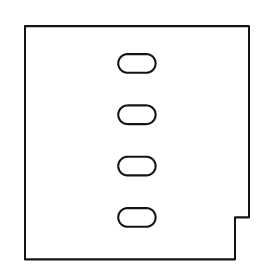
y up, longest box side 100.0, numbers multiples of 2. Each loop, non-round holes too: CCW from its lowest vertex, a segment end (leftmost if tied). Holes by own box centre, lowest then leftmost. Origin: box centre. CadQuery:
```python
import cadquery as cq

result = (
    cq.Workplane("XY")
    .moveTo(-48.0, -50.0)
    .lineTo(42.0, -50.0)
    .lineTo(42.0, -32.0)
    .lineTo(48.0, -32.0)
    .lineTo(48.0, 50.0)
    .lineTo(-48.0, 50.0)
    .close()
    .moveTo(-4.0, -36.0)
    .lineTo(4.0, -36.0)
    .threePointArc((8.0, -32.0), (4.0, -28.0))
    .lineTo(-4.0, -28.0)
    .threePointArc((-8.0, -32.0), (-4.0, -36.0))
    .close()
    .moveTo(-4.0, -14.0)
    .lineTo(4.0, -14.0)
    .threePointArc((8.0, -10.0), (4.0, -6.0))
    .lineTo(-4.0, -6.0)
    .threePointArc((-8.0, -10.0), (-4.0, -14.0))
    .close()
    .moveTo(-4.0, 8.0)
    .lineTo(4.0, 8.0)
    .threePointArc((8.0, 12.0), (4.0, 16.0))
    .lineTo(-4.0, 16.0)
    .threePointArc((-8.0, 12.0), (-4.0, 8.0))
    .close()
    .moveTo(-4.0, 30.0)
    .lineTo(4.0, 30.0)
    .threePointArc((8.0, 34.0), (4.0, 38.0))
    .lineTo(-4.0, 38.0)
    .threePointArc((-8.0, 34.0), (-4.0, 30.0))
    .close()
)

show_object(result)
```